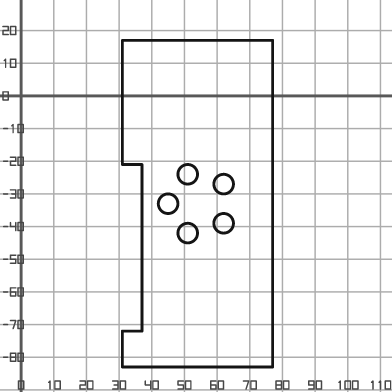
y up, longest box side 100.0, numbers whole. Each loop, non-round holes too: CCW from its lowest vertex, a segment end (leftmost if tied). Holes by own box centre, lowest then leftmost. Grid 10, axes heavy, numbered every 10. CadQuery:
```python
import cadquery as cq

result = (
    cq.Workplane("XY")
    .moveTo(31.0, -83.0)
    .lineTo(77.0, -83.0)
    .lineTo(77.0, 17.0)
    .lineTo(31.0, 17.0)
    .lineTo(31.0, -21.0)
    .lineTo(37.0, -21.0)
    .lineTo(37.0, -72.0)
    .lineTo(31.0, -72.0)
    .close()
    .moveTo(51.0, -42.0)
    .circle(3.0)
    .moveTo(62.0, -39.0)
    .circle(3.0)
    .moveTo(45.0, -33.0)
    .circle(3.0)
    .moveTo(62.0, -27.0)
    .circle(3.0)
    .moveTo(51.0, -24.0)
    .circle(3.0)
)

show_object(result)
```